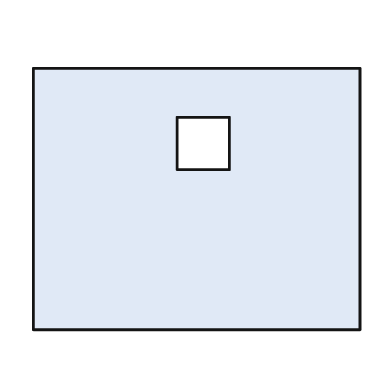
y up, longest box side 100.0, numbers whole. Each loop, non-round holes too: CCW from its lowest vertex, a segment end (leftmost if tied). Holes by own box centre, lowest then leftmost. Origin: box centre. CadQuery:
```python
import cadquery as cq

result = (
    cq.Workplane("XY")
    .moveTo(-50.0, -40.0)
    .lineTo(50.0, -40.0)
    .lineTo(50.0, 40.0)
    .lineTo(-50.0, 40.0)
    .close()
    .moveTo(-6.0, 9.0)
    .lineTo(10.0, 9.0)
    .lineTo(10.0, 25.0)
    .lineTo(-6.0, 25.0)
    .close()
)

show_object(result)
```